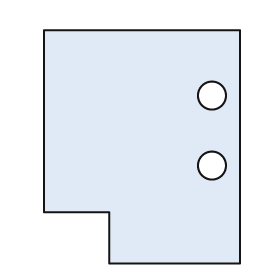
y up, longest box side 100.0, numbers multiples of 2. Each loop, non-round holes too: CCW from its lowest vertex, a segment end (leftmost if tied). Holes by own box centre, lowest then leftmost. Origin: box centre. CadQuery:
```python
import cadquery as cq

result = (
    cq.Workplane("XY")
    .moveTo(-14.0, -50.0)
    .lineTo(42.0, -50.0)
    .lineTo(42.0, 50.0)
    .lineTo(-42.0, 50.0)
    .lineTo(-42.0, -28.0)
    .lineTo(-14.0, -28.0)
    .close()
    .moveTo(30.0, -8.0)
    .circle(6.0)
    .moveTo(30.0, 22.0)
    .circle(6.0)
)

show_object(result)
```